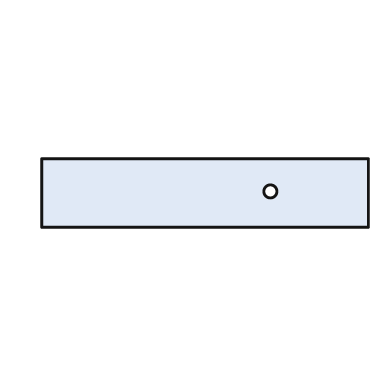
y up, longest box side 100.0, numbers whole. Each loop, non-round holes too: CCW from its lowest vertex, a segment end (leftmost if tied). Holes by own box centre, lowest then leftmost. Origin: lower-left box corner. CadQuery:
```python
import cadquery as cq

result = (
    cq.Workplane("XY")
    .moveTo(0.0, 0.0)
    .lineTo(100.0, 0.0)
    .lineTo(100.0, 21.0)
    .lineTo(0.0, 21.0)
    .close()
    .moveTo(70.0, 11.0)
    .circle(2.0)
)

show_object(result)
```